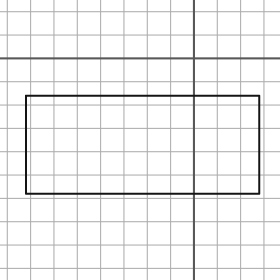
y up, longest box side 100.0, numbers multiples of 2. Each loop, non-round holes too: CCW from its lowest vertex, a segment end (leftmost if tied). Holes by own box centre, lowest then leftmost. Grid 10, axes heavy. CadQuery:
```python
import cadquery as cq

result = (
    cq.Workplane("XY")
    .moveTo(-72.0, -58.0)
    .lineTo(28.0, -58.0)
    .lineTo(28.0, -16.0)
    .lineTo(-72.0, -16.0)
    .close()
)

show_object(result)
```